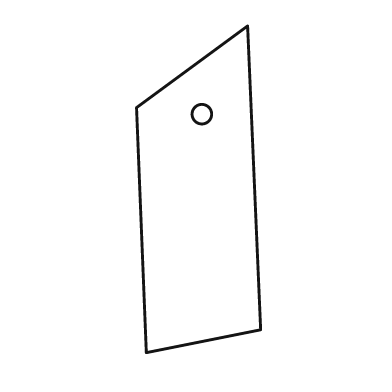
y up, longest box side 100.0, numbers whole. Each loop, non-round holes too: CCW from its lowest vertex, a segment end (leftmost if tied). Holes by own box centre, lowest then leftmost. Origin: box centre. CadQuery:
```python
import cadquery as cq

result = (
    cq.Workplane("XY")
    .moveTo(-16.0, -50.0)
    .lineTo(19.0, -43.0)
    .lineTo(15.0, 50.0)
    .lineTo(-19.0, 25.0)
    .close()
    .moveTo(1.0, 23.0)
    .circle(3.0)
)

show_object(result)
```